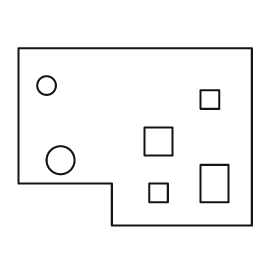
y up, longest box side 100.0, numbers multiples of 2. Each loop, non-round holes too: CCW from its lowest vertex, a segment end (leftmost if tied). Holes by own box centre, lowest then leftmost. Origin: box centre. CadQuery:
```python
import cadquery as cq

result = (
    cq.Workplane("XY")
    .moveTo(-10.0, -38.0)
    .lineTo(50.0, -38.0)
    .lineTo(50.0, 38.0)
    .lineTo(-50.0, 38.0)
    .lineTo(-50.0, -20.0)
    .lineTo(-10.0, -20.0)
    .close()
    .moveTo(6.0, -28.0)
    .lineTo(14.0, -28.0)
    .lineTo(14.0, -20.0)
    .lineTo(6.0, -20.0)
    .close()
    .moveTo(28.0, -28.0)
    .lineTo(40.0, -28.0)
    .lineTo(40.0, -12.0)
    .lineTo(28.0, -12.0)
    .close()
    .moveTo(-32.0, -10.0)
    .circle(6.0)
    .moveTo(4.0, -8.0)
    .lineTo(16.0, -8.0)
    .lineTo(16.0, 4.0)
    .lineTo(4.0, 4.0)
    .close()
    .moveTo(28.0, 12.0)
    .lineTo(36.0, 12.0)
    .lineTo(36.0, 20.0)
    .lineTo(28.0, 20.0)
    .close()
    .moveTo(-38.0, 22.0)
    .circle(4.0)
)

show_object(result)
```